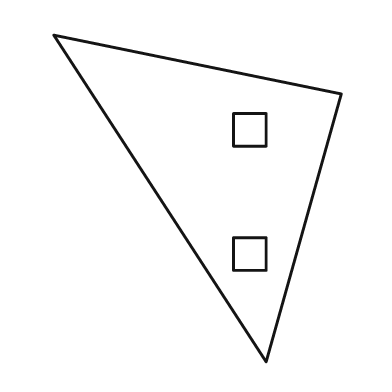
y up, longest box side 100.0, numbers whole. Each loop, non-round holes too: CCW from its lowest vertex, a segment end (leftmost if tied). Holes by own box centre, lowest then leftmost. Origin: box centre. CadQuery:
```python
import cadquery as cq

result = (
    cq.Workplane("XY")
    .moveTo(21.0, -50.0)
    .lineTo(44.0, 32.0)
    .lineTo(-44.0, 50.0)
    .close()
    .moveTo(11.0, -22.0)
    .lineTo(21.0, -22.0)
    .lineTo(21.0, -12.0)
    .lineTo(11.0, -12.0)
    .close()
    .moveTo(11.0, 16.0)
    .lineTo(21.0, 16.0)
    .lineTo(21.0, 26.0)
    .lineTo(11.0, 26.0)
    .close()
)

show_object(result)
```